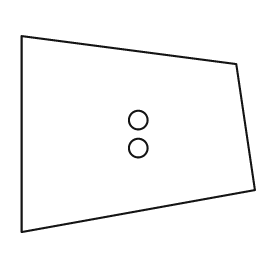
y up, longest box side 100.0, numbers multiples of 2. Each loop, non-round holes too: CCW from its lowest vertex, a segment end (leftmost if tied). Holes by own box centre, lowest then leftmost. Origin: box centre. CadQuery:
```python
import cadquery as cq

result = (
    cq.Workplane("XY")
    .moveTo(-50.0, -42.0)
    .lineTo(50.0, -24.0)
    .lineTo(42.0, 30.0)
    .lineTo(-50.0, 42.0)
    .close()
    .moveTo(0.0, -6.0)
    .circle(4.0)
    .moveTo(0.0, 6.0)
    .circle(4.0)
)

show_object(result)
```